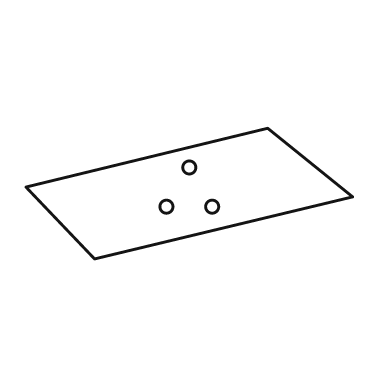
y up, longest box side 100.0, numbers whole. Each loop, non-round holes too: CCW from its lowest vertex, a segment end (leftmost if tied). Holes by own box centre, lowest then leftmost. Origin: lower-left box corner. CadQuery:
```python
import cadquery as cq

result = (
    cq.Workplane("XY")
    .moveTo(21.0, 0.0)
    .lineTo(100.0, 19.0)
    .lineTo(74.0, 40.0)
    .lineTo(0.0, 22.0)
    .close()
    .moveTo(43.0, 16.0)
    .circle(2.0)
    .moveTo(57.0, 16.0)
    .circle(2.0)
    .moveTo(50.0, 28.0)
    .circle(2.0)
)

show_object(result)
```